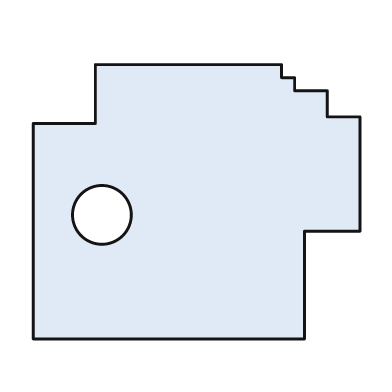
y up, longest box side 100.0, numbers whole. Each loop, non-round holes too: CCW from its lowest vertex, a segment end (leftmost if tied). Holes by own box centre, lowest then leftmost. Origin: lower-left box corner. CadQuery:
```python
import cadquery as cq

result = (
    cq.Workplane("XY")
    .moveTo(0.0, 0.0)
    .lineTo(83.0, 0.0)
    .lineTo(83.0, 33.0)
    .lineTo(100.0, 33.0)
    .lineTo(100.0, 68.0)
    .lineTo(90.0, 68.0)
    .lineTo(90.0, 76.0)
    .lineTo(80.0, 76.0)
    .lineTo(80.0, 80.0)
    .lineTo(76.0, 80.0)
    .lineTo(76.0, 84.0)
    .lineTo(19.0, 84.0)
    .lineTo(19.0, 66.0)
    .lineTo(0.0, 66.0)
    .close()
    .moveTo(21.0, 38.0)
    .circle(9.0)
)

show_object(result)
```